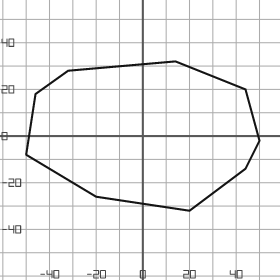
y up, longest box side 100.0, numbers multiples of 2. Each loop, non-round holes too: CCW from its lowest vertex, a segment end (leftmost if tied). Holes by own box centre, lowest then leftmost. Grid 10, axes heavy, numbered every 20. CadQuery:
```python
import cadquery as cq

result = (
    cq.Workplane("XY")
    .moveTo(20.0, -32.0)
    .lineTo(44.0, -14.0)
    .lineTo(50.0, -2.0)
    .lineTo(44.0, 20.0)
    .lineTo(14.0, 32.0)
    .lineTo(-32.0, 28.0)
    .lineTo(-46.0, 18.0)
    .lineTo(-50.0, -8.0)
    .lineTo(-20.0, -26.0)
    .close()
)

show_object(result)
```